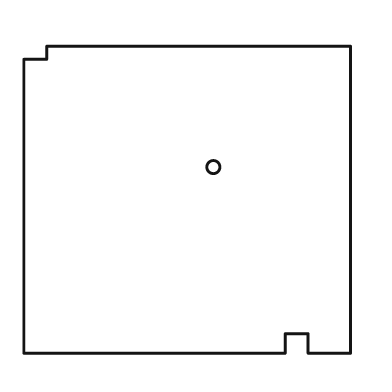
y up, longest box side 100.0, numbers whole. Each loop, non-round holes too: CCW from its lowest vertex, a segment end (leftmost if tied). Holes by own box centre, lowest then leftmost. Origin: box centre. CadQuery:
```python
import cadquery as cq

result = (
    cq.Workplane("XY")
    .moveTo(-50.0, -47.0)
    .lineTo(30.0, -47.0)
    .lineTo(30.0, -41.0)
    .lineTo(37.0, -41.0)
    .lineTo(37.0, -47.0)
    .lineTo(50.0, -47.0)
    .lineTo(50.0, 47.0)
    .lineTo(-43.0, 47.0)
    .lineTo(-43.0, 43.0)
    .lineTo(-50.0, 43.0)
    .close()
    .moveTo(8.0, 10.0)
    .circle(2.0)
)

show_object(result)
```